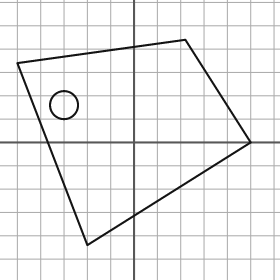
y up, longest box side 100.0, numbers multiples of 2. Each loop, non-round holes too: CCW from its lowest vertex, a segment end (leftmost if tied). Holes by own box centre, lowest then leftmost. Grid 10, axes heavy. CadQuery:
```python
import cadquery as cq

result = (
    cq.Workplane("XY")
    .moveTo(-20.0, -44.0)
    .lineTo(50.0, 0.0)
    .lineTo(22.0, 44.0)
    .lineTo(-50.0, 34.0)
    .close()
    .moveTo(-30.0, 16.0)
    .circle(6.0)
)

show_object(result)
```